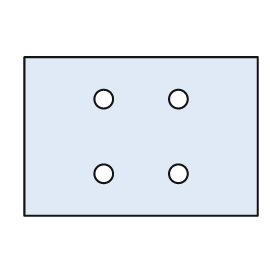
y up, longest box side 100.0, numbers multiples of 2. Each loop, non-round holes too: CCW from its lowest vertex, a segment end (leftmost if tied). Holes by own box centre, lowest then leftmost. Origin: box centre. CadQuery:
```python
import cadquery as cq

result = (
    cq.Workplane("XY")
    .moveTo(-50.0, -34.0)
    .lineTo(50.0, -34.0)
    .lineTo(50.0, 34.0)
    .lineTo(-50.0, 34.0)
    .close()
    .moveTo(-16.0, -16.0)
    .circle(4.0)
    .moveTo(16.0, -16.0)
    .circle(4.0)
    .moveTo(-16.0, 16.0)
    .circle(4.0)
    .moveTo(16.0, 16.0)
    .circle(4.0)
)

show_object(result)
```